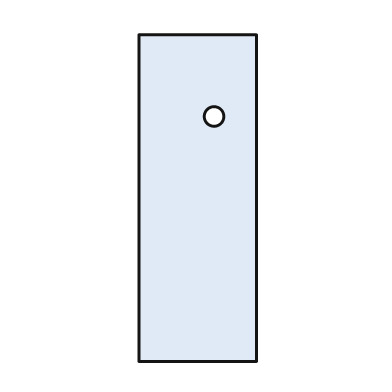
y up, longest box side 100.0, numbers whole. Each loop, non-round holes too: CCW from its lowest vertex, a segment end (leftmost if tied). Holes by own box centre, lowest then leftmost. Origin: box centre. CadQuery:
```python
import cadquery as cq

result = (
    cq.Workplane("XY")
    .moveTo(-18.0, -50.0)
    .lineTo(18.0, -50.0)
    .lineTo(18.0, 50.0)
    .lineTo(-18.0, 50.0)
    .close()
    .moveTo(5.0, 25.0)
    .circle(3.0)
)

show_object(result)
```